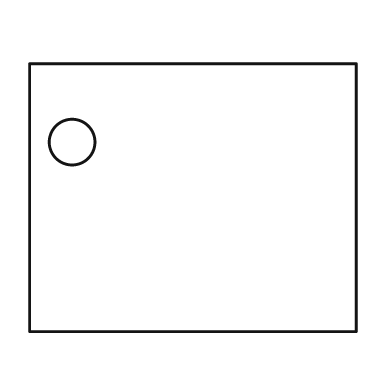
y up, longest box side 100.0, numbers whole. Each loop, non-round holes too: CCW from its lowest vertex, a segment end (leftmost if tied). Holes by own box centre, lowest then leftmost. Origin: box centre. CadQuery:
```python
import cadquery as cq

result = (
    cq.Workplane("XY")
    .moveTo(-50.0, -41.0)
    .lineTo(50.0, -41.0)
    .lineTo(50.0, 41.0)
    .lineTo(-50.0, 41.0)
    .close()
    .moveTo(-37.0, 17.0)
    .circle(7.0)
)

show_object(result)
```